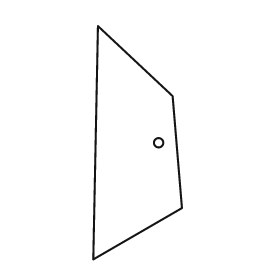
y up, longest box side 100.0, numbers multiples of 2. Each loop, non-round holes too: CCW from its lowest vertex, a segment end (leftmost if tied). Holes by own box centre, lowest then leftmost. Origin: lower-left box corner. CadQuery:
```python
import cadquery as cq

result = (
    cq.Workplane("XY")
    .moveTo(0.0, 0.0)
    .lineTo(38.0, 22.0)
    .lineTo(34.0, 70.0)
    .lineTo(2.0, 100.0)
    .close()
    .moveTo(28.0, 50.0)
    .circle(2.0)
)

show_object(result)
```